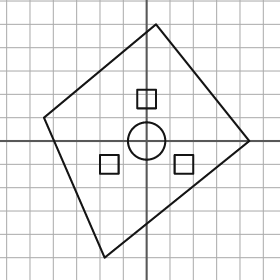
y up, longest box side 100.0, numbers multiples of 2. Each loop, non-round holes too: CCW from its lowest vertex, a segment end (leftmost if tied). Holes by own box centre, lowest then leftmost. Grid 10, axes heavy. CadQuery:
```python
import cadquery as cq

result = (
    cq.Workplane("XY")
    .moveTo(-18.0, -50.0)
    .lineTo(44.0, 0.0)
    .lineTo(4.0, 50.0)
    .lineTo(-44.0, 10.0)
    .close()
    .moveTo(-20.0, -14.0)
    .lineTo(-12.0, -14.0)
    .lineTo(-12.0, -6.0)
    .lineTo(-20.0, -6.0)
    .close()
    .moveTo(12.0, -14.0)
    .lineTo(20.0, -14.0)
    .lineTo(20.0, -6.0)
    .lineTo(12.0, -6.0)
    .close()
    .moveTo(0.0, 0.0)
    .circle(8.0)
    .moveTo(-4.0, 14.0)
    .lineTo(4.0, 14.0)
    .lineTo(4.0, 22.0)
    .lineTo(-4.0, 22.0)
    .close()
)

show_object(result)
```